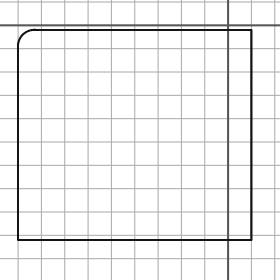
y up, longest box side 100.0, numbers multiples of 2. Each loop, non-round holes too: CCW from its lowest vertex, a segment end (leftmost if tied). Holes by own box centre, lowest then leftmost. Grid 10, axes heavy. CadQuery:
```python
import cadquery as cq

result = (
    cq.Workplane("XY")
    .moveTo(-90.0, -92.0)
    .lineTo(10.0, -92.0)
    .lineTo(10.0, -2.0)
    .lineTo(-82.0, -2.0)
    .threePointArc((-88.0, -4.0), (-90.0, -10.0))
    .close()
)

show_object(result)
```